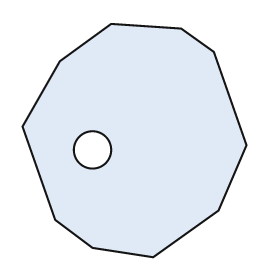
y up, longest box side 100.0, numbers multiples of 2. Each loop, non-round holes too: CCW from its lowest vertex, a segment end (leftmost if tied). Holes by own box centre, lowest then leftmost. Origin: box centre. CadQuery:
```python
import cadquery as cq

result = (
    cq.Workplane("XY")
    .moveTo(8.0, -50.0)
    .lineTo(36.0, -30.0)
    .lineTo(48.0, -2.0)
    .lineTo(34.0, 38.0)
    .lineTo(20.0, 48.0)
    .lineTo(-10.0, 50.0)
    .lineTo(-32.0, 34.0)
    .lineTo(-48.0, 6.0)
    .lineTo(-34.0, -34.0)
    .lineTo(-18.0, -46.0)
    .close()
    .moveTo(-18.0, -4.0)
    .circle(8.0)
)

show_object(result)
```